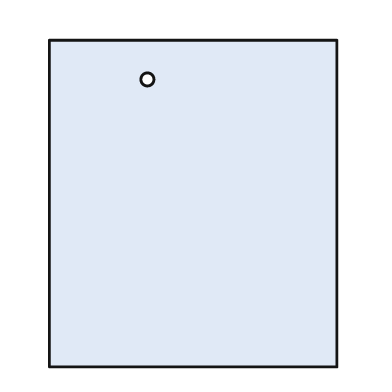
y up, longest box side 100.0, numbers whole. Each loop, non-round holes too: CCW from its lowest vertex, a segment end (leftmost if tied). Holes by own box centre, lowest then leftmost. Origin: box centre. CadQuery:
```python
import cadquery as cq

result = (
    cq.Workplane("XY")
    .moveTo(-44.0, -50.0)
    .lineTo(44.0, -50.0)
    .lineTo(44.0, 50.0)
    .lineTo(-44.0, 50.0)
    .close()
    .moveTo(-14.0, 38.0)
    .circle(2.0)
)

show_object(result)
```